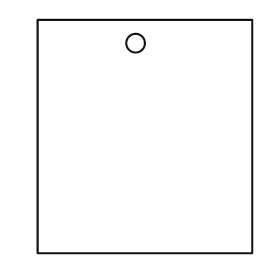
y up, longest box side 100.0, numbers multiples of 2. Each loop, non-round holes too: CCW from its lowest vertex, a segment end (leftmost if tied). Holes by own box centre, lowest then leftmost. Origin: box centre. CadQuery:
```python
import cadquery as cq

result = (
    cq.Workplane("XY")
    .moveTo(-46.0, -50.0)
    .lineTo(46.0, -50.0)
    .lineTo(46.0, 50.0)
    .lineTo(-46.0, 50.0)
    .close()
    .moveTo(-4.0, 40.0)
    .circle(4.0)
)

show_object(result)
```